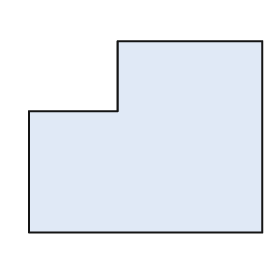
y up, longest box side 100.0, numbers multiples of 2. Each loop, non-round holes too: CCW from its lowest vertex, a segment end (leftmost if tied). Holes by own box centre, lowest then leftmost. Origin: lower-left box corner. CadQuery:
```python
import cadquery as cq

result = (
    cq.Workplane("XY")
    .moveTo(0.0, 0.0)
    .lineTo(100.0, 0.0)
    .lineTo(100.0, 82.0)
    .lineTo(38.0, 82.0)
    .lineTo(38.0, 52.0)
    .lineTo(0.0, 52.0)
    .close()
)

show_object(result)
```